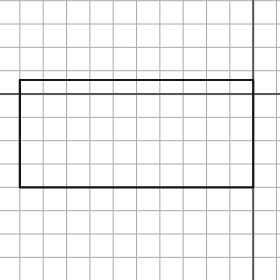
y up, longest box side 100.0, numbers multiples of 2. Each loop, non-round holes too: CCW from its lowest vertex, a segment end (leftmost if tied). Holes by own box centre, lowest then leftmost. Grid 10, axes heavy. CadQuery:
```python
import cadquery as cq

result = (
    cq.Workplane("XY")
    .moveTo(-100.0, -40.0)
    .lineTo(0.0, -40.0)
    .lineTo(0.0, 6.0)
    .lineTo(-100.0, 6.0)
    .close()
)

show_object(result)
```